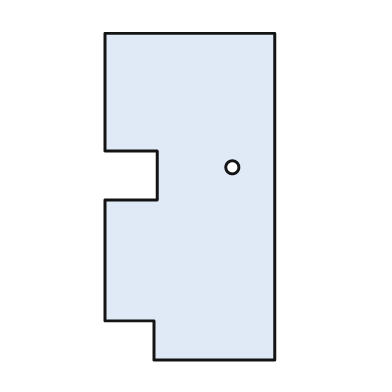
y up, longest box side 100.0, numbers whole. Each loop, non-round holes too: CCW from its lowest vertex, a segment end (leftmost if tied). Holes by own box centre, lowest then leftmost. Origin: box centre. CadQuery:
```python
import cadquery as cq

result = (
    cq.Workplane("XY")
    .moveTo(-11.0, -50.0)
    .lineTo(26.0, -50.0)
    .lineTo(26.0, 50.0)
    .lineTo(-26.0, 50.0)
    .lineTo(-26.0, 14.0)
    .lineTo(-10.0, 14.0)
    .lineTo(-10.0, -1.0)
    .lineTo(-26.0, -1.0)
    .lineTo(-26.0, -38.0)
    .lineTo(-11.0, -38.0)
    .close()
    .moveTo(13.0, 9.0)
    .circle(2.0)
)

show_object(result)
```